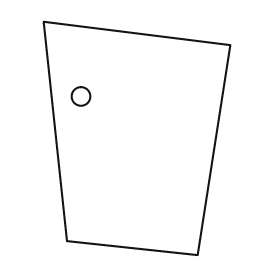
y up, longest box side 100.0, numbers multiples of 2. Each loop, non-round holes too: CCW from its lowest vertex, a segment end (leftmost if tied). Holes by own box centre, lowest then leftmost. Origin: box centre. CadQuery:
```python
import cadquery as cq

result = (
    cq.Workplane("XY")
    .moveTo(26.0, -50.0)
    .lineTo(40.0, 40.0)
    .lineTo(-40.0, 50.0)
    .lineTo(-30.0, -44.0)
    .close()
    .moveTo(-24.0, 18.0)
    .circle(4.0)
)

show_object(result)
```